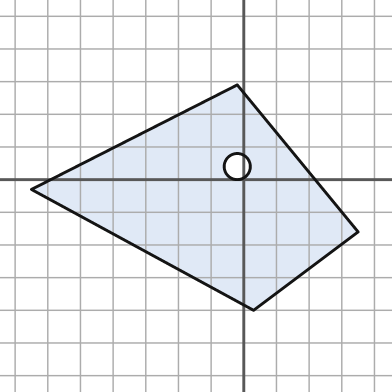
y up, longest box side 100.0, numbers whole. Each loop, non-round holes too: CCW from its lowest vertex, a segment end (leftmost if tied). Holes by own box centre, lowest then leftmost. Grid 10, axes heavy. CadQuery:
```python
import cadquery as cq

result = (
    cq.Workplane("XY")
    .moveTo(3.0, -40.0)
    .lineTo(35.0, -16.0)
    .lineTo(-2.0, 29.0)
    .lineTo(-65.0, -3.0)
    .close()
    .moveTo(-2.0, 4.0)
    .circle(4.0)
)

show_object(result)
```